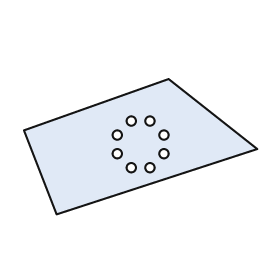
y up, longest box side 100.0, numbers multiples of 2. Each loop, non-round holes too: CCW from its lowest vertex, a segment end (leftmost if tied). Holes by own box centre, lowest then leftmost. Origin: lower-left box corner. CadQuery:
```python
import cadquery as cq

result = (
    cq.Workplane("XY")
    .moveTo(14.0, 0.0)
    .lineTo(100.0, 28.0)
    .lineTo(62.0, 58.0)
    .lineTo(0.0, 36.0)
    .close()
    .moveTo(46.0, 20.0)
    .circle(2.0)
    .moveTo(54.0, 20.0)
    .circle(2.0)
    .moveTo(40.0, 26.0)
    .circle(2.0)
    .moveTo(60.0, 26.0)
    .circle(2.0)
    .moveTo(40.0, 34.0)
    .circle(2.0)
    .moveTo(60.0, 34.0)
    .circle(2.0)
    .moveTo(46.0, 40.0)
    .circle(2.0)
    .moveTo(54.0, 40.0)
    .circle(2.0)
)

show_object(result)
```